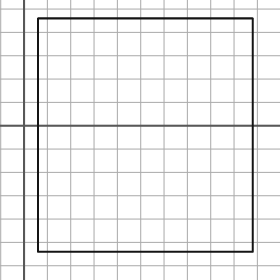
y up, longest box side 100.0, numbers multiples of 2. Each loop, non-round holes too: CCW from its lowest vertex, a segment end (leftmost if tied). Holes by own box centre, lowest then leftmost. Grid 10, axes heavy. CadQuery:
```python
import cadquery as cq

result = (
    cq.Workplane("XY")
    .moveTo(6.0, -54.0)
    .lineTo(98.0, -54.0)
    .lineTo(98.0, 46.0)
    .lineTo(6.0, 46.0)
    .close()
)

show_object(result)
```